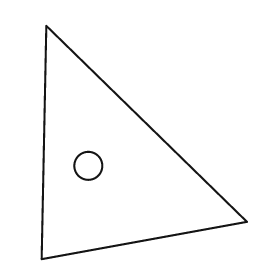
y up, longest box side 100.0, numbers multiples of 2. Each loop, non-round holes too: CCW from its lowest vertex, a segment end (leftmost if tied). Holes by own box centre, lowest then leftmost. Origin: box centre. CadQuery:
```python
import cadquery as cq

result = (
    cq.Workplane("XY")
    .moveTo(-44.0, -50.0)
    .lineTo(44.0, -34.0)
    .lineTo(-42.0, 50.0)
    .close()
    .moveTo(-24.0, -10.0)
    .circle(6.0)
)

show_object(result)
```